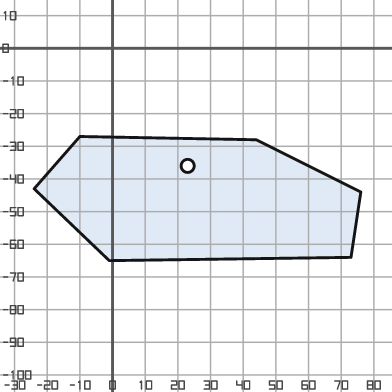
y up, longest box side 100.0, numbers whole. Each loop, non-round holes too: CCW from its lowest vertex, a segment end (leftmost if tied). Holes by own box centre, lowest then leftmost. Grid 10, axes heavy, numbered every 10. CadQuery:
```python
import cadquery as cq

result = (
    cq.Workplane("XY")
    .moveTo(-1.0, -65.0)
    .lineTo(73.0, -64.0)
    .lineTo(76.0, -44.0)
    .lineTo(44.0, -28.0)
    .lineTo(-10.0, -27.0)
    .lineTo(-24.0, -43.0)
    .close()
    .moveTo(23.0, -36.0)
    .circle(2.0)
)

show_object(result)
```